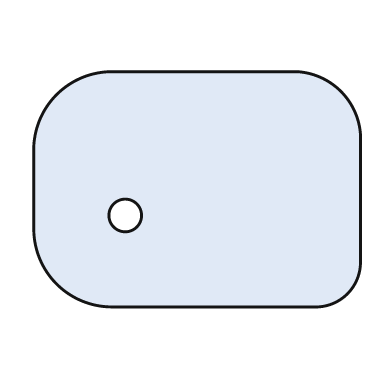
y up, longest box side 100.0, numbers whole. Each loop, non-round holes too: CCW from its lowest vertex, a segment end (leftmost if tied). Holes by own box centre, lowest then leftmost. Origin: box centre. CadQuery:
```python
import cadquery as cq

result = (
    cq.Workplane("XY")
    .moveTo(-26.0, -36.0)
    .lineTo(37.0, -36.0)
    .threePointArc((46.0, -32.0), (50.0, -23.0))
    .lineTo(50.0, 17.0)
    .threePointArc((44.0, 30.0), (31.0, 36.0))
    .lineTo(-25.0, 36.0)
    .threePointArc((-43.0, 29.0), (-50.0, 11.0))
    .lineTo(-50.0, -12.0)
    .threePointArc((-43.0, -29.0), (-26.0, -36.0))
    .close()
    .moveTo(-22.0, -8.0)
    .circle(5.0)
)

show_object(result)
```